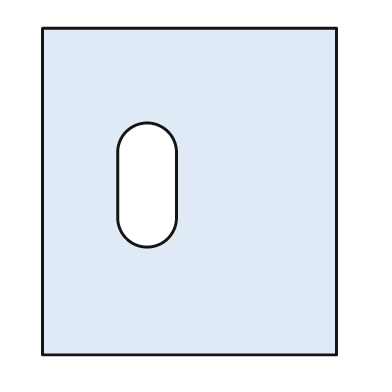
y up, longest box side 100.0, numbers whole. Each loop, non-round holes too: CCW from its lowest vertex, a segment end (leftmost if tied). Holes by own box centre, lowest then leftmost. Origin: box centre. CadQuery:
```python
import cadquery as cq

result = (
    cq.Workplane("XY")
    .moveTo(-45.0, -50.0)
    .lineTo(45.0, -50.0)
    .lineTo(45.0, 50.0)
    .lineTo(-45.0, 50.0)
    .close()
    .moveTo(-22.0, -8.0)
    .threePointArc((-13.0, -17.0), (-4.0, -8.0))
    .lineTo(-4.0, 12.0)
    .threePointArc((-13.0, 21.0), (-22.0, 12.0))
    .close()
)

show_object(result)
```